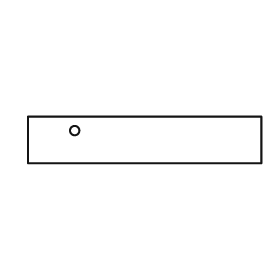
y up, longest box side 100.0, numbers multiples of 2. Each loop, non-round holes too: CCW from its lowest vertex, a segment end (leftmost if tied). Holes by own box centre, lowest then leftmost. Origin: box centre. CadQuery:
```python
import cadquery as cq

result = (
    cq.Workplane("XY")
    .moveTo(-50.0, -10.0)
    .lineTo(50.0, -10.0)
    .lineTo(50.0, 10.0)
    .lineTo(-50.0, 10.0)
    .close()
    .moveTo(-30.0, 4.0)
    .circle(2.0)
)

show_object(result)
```